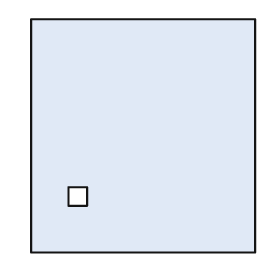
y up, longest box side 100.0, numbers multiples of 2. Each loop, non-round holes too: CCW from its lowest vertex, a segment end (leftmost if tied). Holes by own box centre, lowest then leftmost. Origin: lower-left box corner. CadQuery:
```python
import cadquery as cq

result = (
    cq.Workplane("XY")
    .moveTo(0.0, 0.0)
    .lineTo(96.0, 0.0)
    .lineTo(96.0, 100.0)
    .lineTo(0.0, 100.0)
    .close()
    .moveTo(16.0, 20.0)
    .lineTo(24.0, 20.0)
    .lineTo(24.0, 28.0)
    .lineTo(16.0, 28.0)
    .close()
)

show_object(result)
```